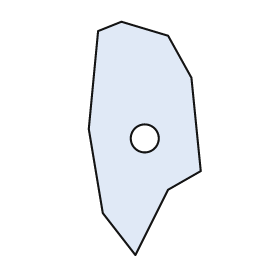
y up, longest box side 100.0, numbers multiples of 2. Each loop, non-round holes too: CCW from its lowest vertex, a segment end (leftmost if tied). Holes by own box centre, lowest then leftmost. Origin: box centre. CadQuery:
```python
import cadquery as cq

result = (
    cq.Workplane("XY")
    .moveTo(-4.0, -50.0)
    .lineTo(10.0, -22.0)
    .lineTo(24.0, -14.0)
    .lineTo(20.0, 26.0)
    .lineTo(10.0, 44.0)
    .lineTo(-10.0, 50.0)
    .lineTo(-20.0, 46.0)
    .lineTo(-24.0, 4.0)
    .lineTo(-18.0, -32.0)
    .close()
    .moveTo(0.0, 0.0)
    .circle(6.0)
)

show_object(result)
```